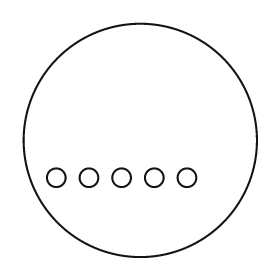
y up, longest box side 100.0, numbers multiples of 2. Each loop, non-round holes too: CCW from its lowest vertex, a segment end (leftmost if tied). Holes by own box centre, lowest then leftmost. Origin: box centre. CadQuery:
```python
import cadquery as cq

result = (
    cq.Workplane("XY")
    .moveTo(0.0, 0.0)
    .circle(50.0)
    .moveTo(-36.0, -16.0)
    .circle(4.0)
    .moveTo(-22.0, -16.0)
    .circle(4.0)
    .moveTo(-8.0, -16.0)
    .circle(4.0)
    .moveTo(6.0, -16.0)
    .circle(4.0)
    .moveTo(20.0, -16.0)
    .circle(4.0)
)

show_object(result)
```